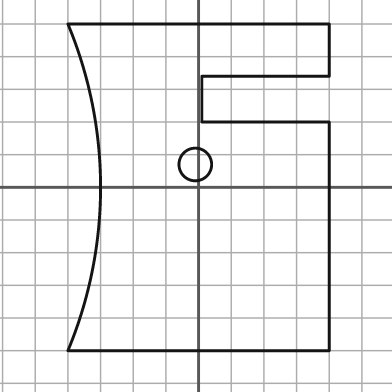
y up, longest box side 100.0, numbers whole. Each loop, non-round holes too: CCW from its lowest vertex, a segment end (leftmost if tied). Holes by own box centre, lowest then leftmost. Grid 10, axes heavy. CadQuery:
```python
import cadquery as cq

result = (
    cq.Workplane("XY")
    .moveTo(-40.0, -50.0)
    .lineTo(40.0, -50.0)
    .lineTo(40.0, 20.0)
    .lineTo(1.0, 20.0)
    .lineTo(1.0, 34.0)
    .lineTo(40.0, 34.0)
    .lineTo(40.0, 50.0)
    .lineTo(-40.0, 50.0)
    .threePointArc((-30.0, 0.0), (-40.0, -50.0))
    .close()
    .moveTo(-1.0, 7.0)
    .circle(5.0)
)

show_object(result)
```